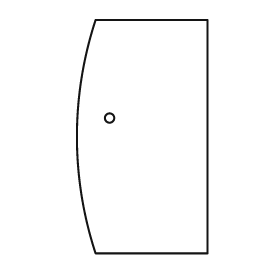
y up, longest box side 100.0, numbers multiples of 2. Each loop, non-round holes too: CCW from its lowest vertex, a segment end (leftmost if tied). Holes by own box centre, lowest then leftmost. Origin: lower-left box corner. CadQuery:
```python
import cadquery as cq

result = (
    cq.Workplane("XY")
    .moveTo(8.0, 0.0)
    .lineTo(56.0, 0.0)
    .lineTo(56.0, 100.0)
    .lineTo(8.0, 100.0)
    .threePointArc((0.0, 50.0), (8.0, 0.0))
    .close()
    .moveTo(14.0, 58.0)
    .circle(2.0)
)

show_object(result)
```